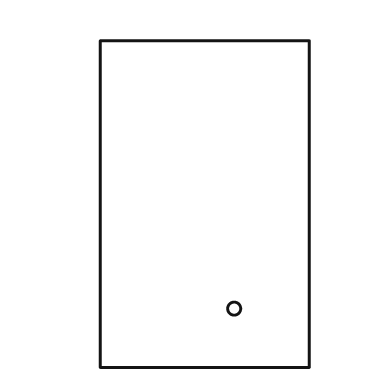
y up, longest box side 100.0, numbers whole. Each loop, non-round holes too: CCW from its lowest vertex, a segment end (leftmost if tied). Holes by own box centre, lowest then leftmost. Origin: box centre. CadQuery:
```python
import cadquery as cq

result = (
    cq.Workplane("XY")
    .moveTo(-32.0, -50.0)
    .lineTo(32.0, -50.0)
    .lineTo(32.0, 50.0)
    .lineTo(-32.0, 50.0)
    .close()
    .moveTo(9.0, -32.0)
    .circle(2.0)
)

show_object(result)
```